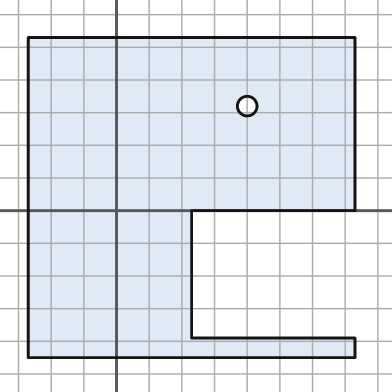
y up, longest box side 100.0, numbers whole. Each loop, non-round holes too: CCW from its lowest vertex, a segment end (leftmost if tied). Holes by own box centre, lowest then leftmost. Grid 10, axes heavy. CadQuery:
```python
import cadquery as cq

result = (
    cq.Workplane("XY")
    .moveTo(-27.0, -45.0)
    .lineTo(73.0, -45.0)
    .lineTo(73.0, -39.0)
    .lineTo(23.0, -39.0)
    .lineTo(23.0, 0.0)
    .lineTo(73.0, 0.0)
    .lineTo(73.0, 53.0)
    .lineTo(-27.0, 53.0)
    .close()
    .moveTo(40.0, 32.0)
    .circle(3.0)
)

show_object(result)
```